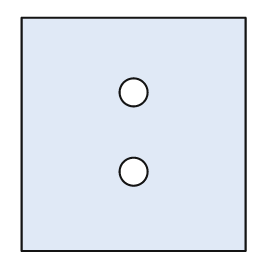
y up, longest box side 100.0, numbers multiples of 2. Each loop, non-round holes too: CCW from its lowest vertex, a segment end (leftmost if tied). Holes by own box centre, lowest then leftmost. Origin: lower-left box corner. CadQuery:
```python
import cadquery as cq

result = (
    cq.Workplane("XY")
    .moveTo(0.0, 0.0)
    .lineTo(96.0, 0.0)
    .lineTo(96.0, 100.0)
    .lineTo(0.0, 100.0)
    .close()
    .moveTo(48.0, 34.0)
    .circle(6.0)
    .moveTo(48.0, 68.0)
    .circle(6.0)
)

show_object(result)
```